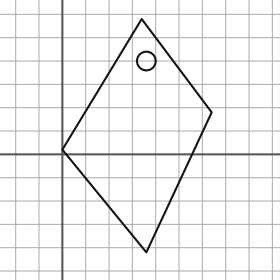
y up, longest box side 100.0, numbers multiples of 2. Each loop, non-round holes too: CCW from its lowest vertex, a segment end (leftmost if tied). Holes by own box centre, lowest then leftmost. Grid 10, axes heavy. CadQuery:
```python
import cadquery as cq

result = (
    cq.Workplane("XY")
    .moveTo(36.0, -42.0)
    .lineTo(64.0, 18.0)
    .lineTo(34.0, 58.0)
    .lineTo(0.0, 2.0)
    .close()
    .moveTo(36.0, 40.0)
    .circle(4.0)
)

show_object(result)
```